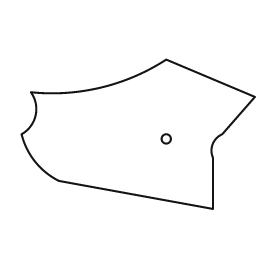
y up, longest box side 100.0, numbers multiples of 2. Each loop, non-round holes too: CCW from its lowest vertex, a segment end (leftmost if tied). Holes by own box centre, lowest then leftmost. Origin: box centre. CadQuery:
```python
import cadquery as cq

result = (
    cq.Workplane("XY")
    .moveTo(32.0, -32.0)
    .lineTo(32.0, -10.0)
    .threePointArc((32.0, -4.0), (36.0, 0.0))
    .lineTo(50.0, 16.0)
    .lineTo(12.0, 32.0)
    .threePointArc((-16.0, 20.0), (-46.0, 18.0))
    .threePointArc((-44.0, 8.0), (-50.0, 0.0))
    .threePointArc((-44.0, -12.0), (-34.0, -20.0))
    .close()
    .moveTo(12.0, -2.0)
    .circle(2.0)
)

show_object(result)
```